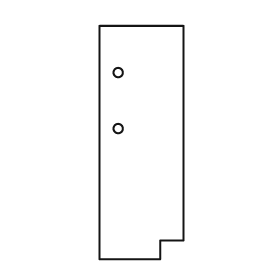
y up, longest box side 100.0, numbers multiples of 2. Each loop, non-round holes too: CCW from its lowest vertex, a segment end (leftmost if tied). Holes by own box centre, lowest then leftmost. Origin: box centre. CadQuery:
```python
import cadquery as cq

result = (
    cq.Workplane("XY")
    .moveTo(-18.0, -50.0)
    .lineTo(8.0, -50.0)
    .lineTo(8.0, -42.0)
    .lineTo(18.0, -42.0)
    .lineTo(18.0, 50.0)
    .lineTo(-18.0, 50.0)
    .close()
    .moveTo(-10.0, 6.0)
    .circle(2.0)
    .moveTo(-10.0, 30.0)
    .circle(2.0)
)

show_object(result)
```